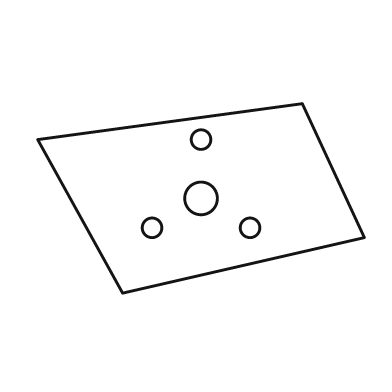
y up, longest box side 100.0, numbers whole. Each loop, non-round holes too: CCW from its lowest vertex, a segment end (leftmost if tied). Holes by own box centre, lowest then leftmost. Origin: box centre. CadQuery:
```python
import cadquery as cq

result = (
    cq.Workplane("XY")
    .moveTo(-24.0, -29.0)
    .lineTo(50.0, -12.0)
    .lineTo(31.0, 29.0)
    .lineTo(-50.0, 18.0)
    .close()
    .moveTo(-15.0, -9.0)
    .circle(3.0)
    .moveTo(15.0, -9.0)
    .circle(3.0)
    .moveTo(0.0, 0.0)
    .circle(5.0)
    .moveTo(0.0, 18.0)
    .circle(3.0)
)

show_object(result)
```